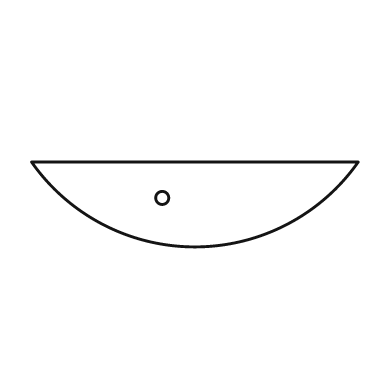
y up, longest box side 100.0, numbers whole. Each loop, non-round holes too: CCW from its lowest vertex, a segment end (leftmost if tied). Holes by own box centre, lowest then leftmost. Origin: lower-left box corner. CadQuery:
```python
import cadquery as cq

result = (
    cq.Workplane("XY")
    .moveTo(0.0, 26.0)
    .threePointArc((50.0, 0.0), (100.0, 26.0))
    .close()
    .moveTo(40.0, 15.0)
    .circle(2.0)
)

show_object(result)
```